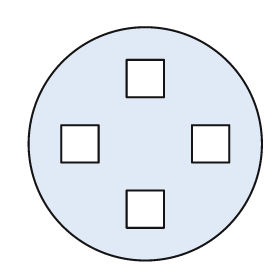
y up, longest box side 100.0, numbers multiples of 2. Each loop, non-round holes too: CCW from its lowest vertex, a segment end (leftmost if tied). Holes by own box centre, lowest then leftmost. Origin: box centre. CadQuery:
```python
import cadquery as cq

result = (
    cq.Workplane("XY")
    .moveTo(0.0, 0.0)
    .circle(50.0)
    .moveTo(-8.0, -36.0)
    .lineTo(8.0, -36.0)
    .lineTo(8.0, -20.0)
    .lineTo(-8.0, -20.0)
    .close()
    .moveTo(-36.0, -8.0)
    .lineTo(-20.0, -8.0)
    .lineTo(-20.0, 8.0)
    .lineTo(-36.0, 8.0)
    .close()
    .moveTo(20.0, -8.0)
    .lineTo(36.0, -8.0)
    .lineTo(36.0, 8.0)
    .lineTo(20.0, 8.0)
    .close()
    .moveTo(-8.0, 20.0)
    .lineTo(8.0, 20.0)
    .lineTo(8.0, 36.0)
    .lineTo(-8.0, 36.0)
    .close()
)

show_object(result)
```